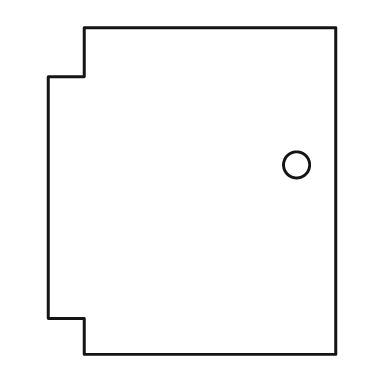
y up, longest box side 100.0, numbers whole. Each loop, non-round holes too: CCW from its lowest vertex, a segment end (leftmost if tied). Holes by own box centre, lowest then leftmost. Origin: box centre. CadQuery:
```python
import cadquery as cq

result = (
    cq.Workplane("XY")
    .moveTo(-33.0, -50.0)
    .lineTo(44.0, -50.0)
    .lineTo(44.0, 50.0)
    .lineTo(-33.0, 50.0)
    .lineTo(-33.0, 35.0)
    .lineTo(-44.0, 35.0)
    .lineTo(-44.0, -39.0)
    .lineTo(-33.0, -39.0)
    .close()
    .moveTo(32.0, 8.0)
    .circle(4.0)
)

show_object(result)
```